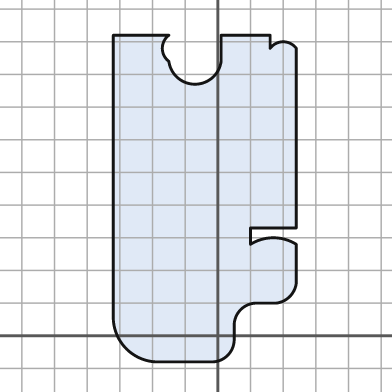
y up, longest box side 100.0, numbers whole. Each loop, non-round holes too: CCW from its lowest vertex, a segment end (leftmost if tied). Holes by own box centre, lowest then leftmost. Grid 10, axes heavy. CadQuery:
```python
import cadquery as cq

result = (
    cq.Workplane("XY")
    .moveTo(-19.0, -8.0)
    .lineTo(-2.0, -8.0)
    .threePointArc((3.0, -6.0), (5.0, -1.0))
    .lineTo(5.0, 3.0)
    .threePointArc((7.0, 8.0), (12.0, 10.0))
    .lineTo(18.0, 10.0)
    .threePointArc((22.0, 12.0), (24.0, 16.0))
    .lineTo(24.0, 28.0)
    .threePointArc((17.0, 30.0), (10.0, 28.0))
    .lineTo(10.0, 33.0)
    .lineTo(24.0, 33.0)
    .lineTo(24.0, 88.0)
    .threePointArc((20.0, 90.0), (16.0, 88.0))
    .lineTo(16.0, 92.0)
    .lineTo(1.0, 92.0)
    .lineTo(1.0, 84.0)
    .threePointArc((-7.0, 77.0), (-15.0, 84.0))
    .threePointArc((-17.0, 88.0), (-15.0, 92.0))
    .lineTo(-32.0, 92.0)
    .lineTo(-32.0, 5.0)
    .threePointArc((-28.0, -4.0), (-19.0, -8.0))
    .close()
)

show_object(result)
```